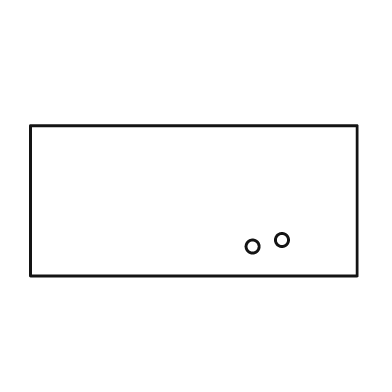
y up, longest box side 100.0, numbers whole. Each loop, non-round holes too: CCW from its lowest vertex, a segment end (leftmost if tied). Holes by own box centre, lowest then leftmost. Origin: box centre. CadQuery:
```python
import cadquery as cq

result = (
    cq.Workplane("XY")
    .moveTo(-50.0, -23.0)
    .lineTo(50.0, -23.0)
    .lineTo(50.0, 23.0)
    .lineTo(-50.0, 23.0)
    .close()
    .moveTo(18.0, -14.0)
    .circle(2.0)
    .moveTo(27.0, -12.0)
    .circle(2.0)
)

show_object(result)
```